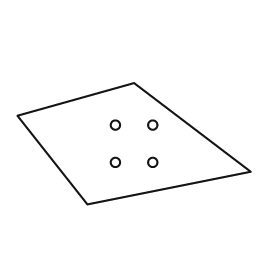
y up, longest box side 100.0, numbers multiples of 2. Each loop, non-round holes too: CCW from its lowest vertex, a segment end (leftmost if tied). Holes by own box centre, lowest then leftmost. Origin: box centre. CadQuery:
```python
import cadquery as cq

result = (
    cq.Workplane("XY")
    .moveTo(-20.0, -26.0)
    .lineTo(50.0, -12.0)
    .lineTo(0.0, 26.0)
    .lineTo(-50.0, 12.0)
    .close()
    .moveTo(-8.0, -8.0)
    .circle(2.0)
    .moveTo(8.0, -8.0)
    .circle(2.0)
    .moveTo(-8.0, 8.0)
    .circle(2.0)
    .moveTo(8.0, 8.0)
    .circle(2.0)
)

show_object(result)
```